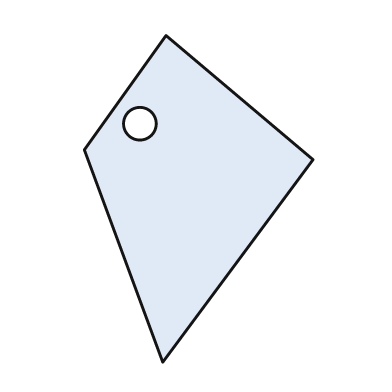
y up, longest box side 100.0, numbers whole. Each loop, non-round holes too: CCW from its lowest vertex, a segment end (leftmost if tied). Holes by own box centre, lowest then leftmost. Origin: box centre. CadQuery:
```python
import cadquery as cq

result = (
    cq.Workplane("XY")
    .moveTo(-11.0, -50.0)
    .lineTo(35.0, 12.0)
    .lineTo(-10.0, 50.0)
    .lineTo(-35.0, 15.0)
    .close()
    .moveTo(-18.0, 23.0)
    .circle(5.0)
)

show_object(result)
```